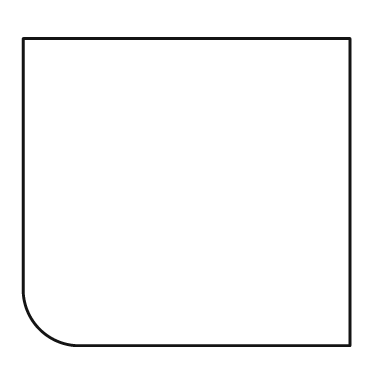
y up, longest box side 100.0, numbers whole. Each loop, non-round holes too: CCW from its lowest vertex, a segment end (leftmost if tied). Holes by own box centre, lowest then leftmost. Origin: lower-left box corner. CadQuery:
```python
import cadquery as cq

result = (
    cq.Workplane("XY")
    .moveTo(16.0, 0.0)
    .lineTo(100.0, 0.0)
    .lineTo(100.0, 94.0)
    .lineTo(0.0, 94.0)
    .lineTo(0.0, 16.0)
    .threePointArc((5.0, 5.0), (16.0, 0.0))
    .close()
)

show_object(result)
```